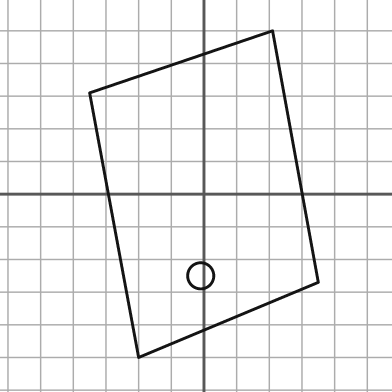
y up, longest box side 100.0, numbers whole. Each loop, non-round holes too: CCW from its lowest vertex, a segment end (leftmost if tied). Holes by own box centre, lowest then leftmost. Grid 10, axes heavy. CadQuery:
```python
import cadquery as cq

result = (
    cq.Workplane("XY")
    .moveTo(-20.0, -50.0)
    .lineTo(35.0, -27.0)
    .lineTo(21.0, 50.0)
    .lineTo(-35.0, 31.0)
    .close()
    .moveTo(-1.0, -25.0)
    .circle(4.0)
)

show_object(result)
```